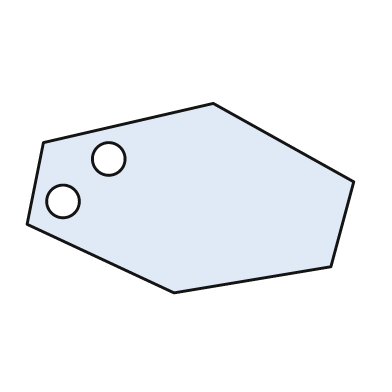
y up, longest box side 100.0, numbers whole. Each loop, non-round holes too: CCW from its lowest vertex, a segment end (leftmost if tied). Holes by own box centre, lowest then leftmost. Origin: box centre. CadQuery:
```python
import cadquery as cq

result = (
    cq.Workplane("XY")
    .moveTo(-5.0, -29.0)
    .lineTo(43.0, -21.0)
    .lineTo(50.0, 5.0)
    .lineTo(7.0, 29.0)
    .lineTo(-45.0, 17.0)
    .lineTo(-50.0, -8.0)
    .close()
    .moveTo(-39.0, -1.0)
    .circle(5.0)
    .moveTo(-25.0, 12.0)
    .circle(5.0)
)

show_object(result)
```